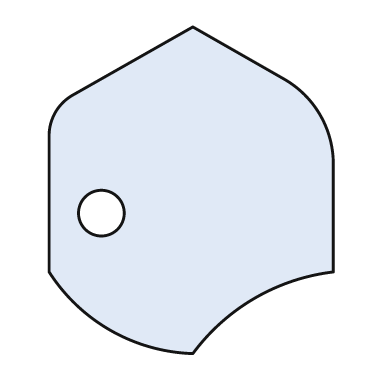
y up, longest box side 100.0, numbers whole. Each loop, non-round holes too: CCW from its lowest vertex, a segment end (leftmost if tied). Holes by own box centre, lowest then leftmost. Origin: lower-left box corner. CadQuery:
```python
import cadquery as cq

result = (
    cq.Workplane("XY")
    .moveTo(44.0, 0.0)
    .threePointArc((63.0, 17.0), (87.0, 25.0))
    .lineTo(87.0, 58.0)
    .threePointArc((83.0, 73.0), (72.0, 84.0))
    .lineTo(44.0, 100.0)
    .lineTo(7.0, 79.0)
    .threePointArc((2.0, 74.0), (0.0, 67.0))
    .lineTo(0.0, 25.0)
    .threePointArc((19.0, 7.0), (44.0, 0.0))
    .close()
    .moveTo(16.0, 43.0)
    .circle(7.0)
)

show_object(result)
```